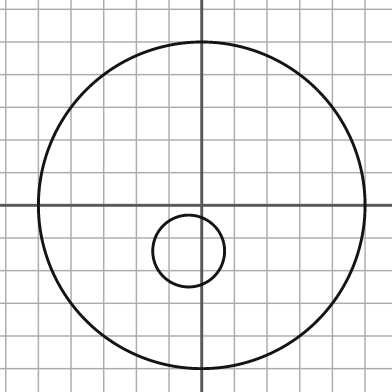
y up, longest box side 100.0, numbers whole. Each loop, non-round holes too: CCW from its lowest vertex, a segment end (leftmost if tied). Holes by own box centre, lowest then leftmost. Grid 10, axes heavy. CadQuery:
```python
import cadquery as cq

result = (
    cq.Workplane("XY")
    .moveTo(0.0, 0.0)
    .circle(50.0)
    .moveTo(-4.0, -14.0)
    .circle(11.0)
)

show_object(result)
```